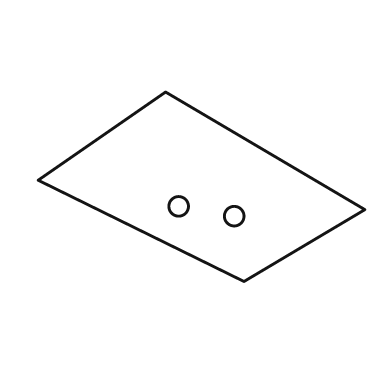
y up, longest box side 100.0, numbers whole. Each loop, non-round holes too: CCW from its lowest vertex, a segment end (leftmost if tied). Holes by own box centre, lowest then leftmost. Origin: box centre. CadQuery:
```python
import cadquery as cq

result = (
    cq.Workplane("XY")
    .moveTo(13.0, -29.0)
    .lineTo(50.0, -7.0)
    .lineTo(-11.0, 29.0)
    .lineTo(-50.0, 2.0)
    .close()
    .moveTo(10.0, -9.0)
    .circle(3.0)
    .moveTo(-7.0, -6.0)
    .circle(3.0)
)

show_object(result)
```